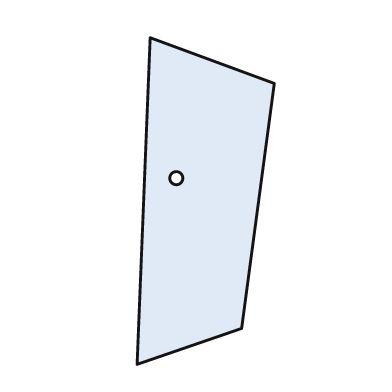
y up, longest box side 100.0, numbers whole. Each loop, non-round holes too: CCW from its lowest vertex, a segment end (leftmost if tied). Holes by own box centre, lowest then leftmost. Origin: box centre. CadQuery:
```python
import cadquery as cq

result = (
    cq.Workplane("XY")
    .moveTo(-21.0, -50.0)
    .lineTo(11.0, -39.0)
    .lineTo(21.0, 36.0)
    .lineTo(-17.0, 50.0)
    .close()
    .moveTo(-9.0, 7.0)
    .circle(2.0)
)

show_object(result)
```